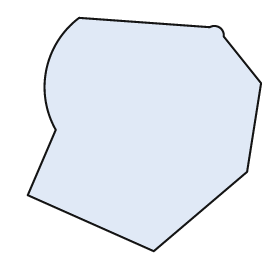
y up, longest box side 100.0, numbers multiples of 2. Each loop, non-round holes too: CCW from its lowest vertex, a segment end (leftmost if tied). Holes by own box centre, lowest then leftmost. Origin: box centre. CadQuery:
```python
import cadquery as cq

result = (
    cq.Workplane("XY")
    .moveTo(4.0, -50.0)
    .lineTo(44.0, -16.0)
    .lineTo(50.0, 22.0)
    .lineTo(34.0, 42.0)
    .threePointArc((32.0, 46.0), (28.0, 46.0))
    .lineTo(-28.0, 50.0)
    .threePointArc((-42.0, 28.0), (-38.0, 2.0))
    .lineTo(-50.0, -26.0)
    .close()
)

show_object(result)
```